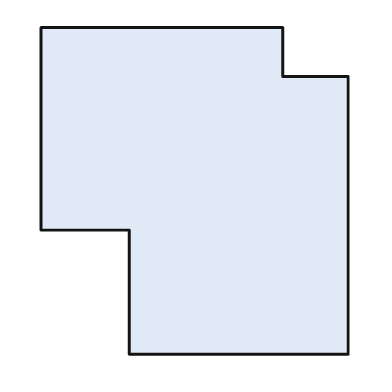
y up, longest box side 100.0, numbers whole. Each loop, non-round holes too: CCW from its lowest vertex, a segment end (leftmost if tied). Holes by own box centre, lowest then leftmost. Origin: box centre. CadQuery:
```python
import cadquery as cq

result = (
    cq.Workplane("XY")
    .moveTo(-20.0, -50.0)
    .lineTo(47.0, -50.0)
    .lineTo(47.0, 35.0)
    .lineTo(27.0, 35.0)
    .lineTo(27.0, 50.0)
    .lineTo(-47.0, 50.0)
    .lineTo(-47.0, -12.0)
    .lineTo(-20.0, -12.0)
    .close()
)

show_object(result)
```